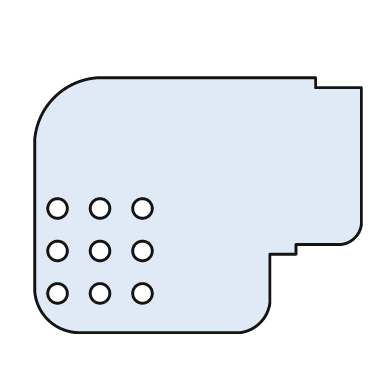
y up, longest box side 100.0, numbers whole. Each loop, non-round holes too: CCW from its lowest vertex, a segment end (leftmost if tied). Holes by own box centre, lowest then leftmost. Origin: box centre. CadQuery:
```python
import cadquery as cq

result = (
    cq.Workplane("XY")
    .moveTo(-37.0, -39.0)
    .lineTo(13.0, -39.0)
    .threePointArc((19.0, -36.0), (22.0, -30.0))
    .lineTo(22.0, -15.0)
    .lineTo(30.0, -15.0)
    .lineTo(30.0, -12.0)
    .lineTo(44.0, -12.0)
    .threePointArc((48.0, -10.0), (50.0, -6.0))
    .lineTo(50.0, 36.0)
    .lineTo(36.0, 36.0)
    .lineTo(36.0, 39.0)
    .lineTo(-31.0, 39.0)
    .threePointArc((-44.0, 33.0), (-50.0, 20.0))
    .lineTo(-50.0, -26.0)
    .threePointArc((-46.0, -35.0), (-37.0, -39.0))
    .close()
    .moveTo(-43.0, -27.0)
    .circle(3.0)
    .moveTo(-30.0, -27.0)
    .circle(3.0)
    .moveTo(-17.0, -27.0)
    .circle(3.0)
    .moveTo(-43.0, -14.0)
    .circle(3.0)
    .moveTo(-30.0, -14.0)
    .circle(3.0)
    .moveTo(-17.0, -14.0)
    .circle(3.0)
    .moveTo(-43.0, -1.0)
    .circle(3.0)
    .moveTo(-30.0, -1.0)
    .circle(3.0)
    .moveTo(-17.0, -1.0)
    .circle(3.0)
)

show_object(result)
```